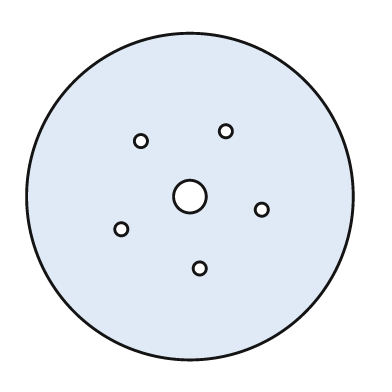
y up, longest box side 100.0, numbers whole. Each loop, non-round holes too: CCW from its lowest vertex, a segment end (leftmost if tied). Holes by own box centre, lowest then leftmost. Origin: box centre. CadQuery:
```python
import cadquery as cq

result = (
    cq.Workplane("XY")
    .moveTo(0.0, 0.0)
    .circle(50.0)
    .moveTo(3.0, -22.0)
    .circle(2.0)
    .moveTo(-21.0, -10.0)
    .circle(2.0)
    .moveTo(22.0, -4.0)
    .circle(2.0)
    .moveTo(0.0, 0.0)
    .circle(5.0)
    .moveTo(-15.0, 17.0)
    .circle(2.0)
    .moveTo(11.0, 20.0)
    .circle(2.0)
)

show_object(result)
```